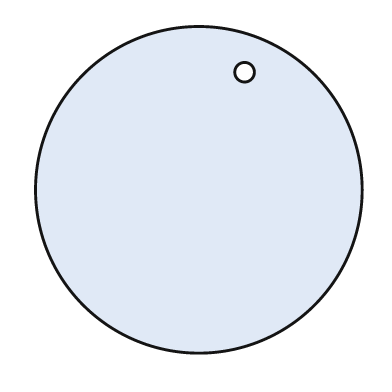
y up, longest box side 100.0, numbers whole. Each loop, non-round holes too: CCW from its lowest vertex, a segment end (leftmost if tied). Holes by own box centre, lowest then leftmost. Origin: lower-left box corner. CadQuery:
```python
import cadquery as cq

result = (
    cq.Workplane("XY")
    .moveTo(50.0, 50.0)
    .circle(50.0)
    .moveTo(64.0, 86.0)
    .circle(3.0)
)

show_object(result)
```